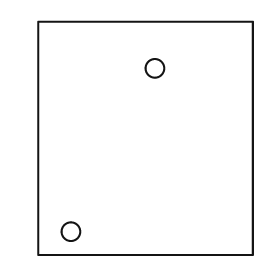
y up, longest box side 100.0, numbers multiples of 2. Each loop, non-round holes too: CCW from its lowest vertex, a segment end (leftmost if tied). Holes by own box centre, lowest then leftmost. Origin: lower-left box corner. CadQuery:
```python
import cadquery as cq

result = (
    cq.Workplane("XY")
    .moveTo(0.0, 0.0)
    .lineTo(92.0, 0.0)
    .lineTo(92.0, 100.0)
    .lineTo(0.0, 100.0)
    .close()
    .moveTo(14.0, 10.0)
    .circle(4.0)
    .moveTo(50.0, 80.0)
    .circle(4.0)
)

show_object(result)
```